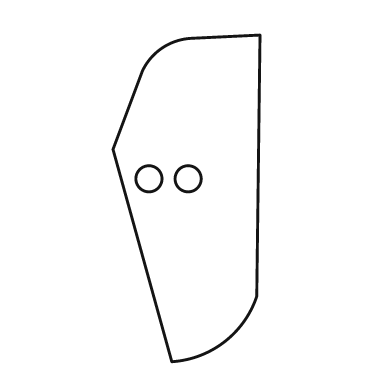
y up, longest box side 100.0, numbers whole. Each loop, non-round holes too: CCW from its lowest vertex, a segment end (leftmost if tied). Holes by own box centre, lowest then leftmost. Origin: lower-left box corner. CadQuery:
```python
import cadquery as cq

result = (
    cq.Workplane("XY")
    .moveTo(18.0, 0.0)
    .threePointArc((34.0, 6.0), (44.0, 20.0))
    .lineTo(45.0, 100.0)
    .lineTo(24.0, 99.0)
    .threePointArc((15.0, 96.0), (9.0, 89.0))
    .lineTo(0.0, 65.0)
    .close()
    .moveTo(11.0, 56.0)
    .circle(4.0)
    .moveTo(23.0, 56.0)
    .circle(4.0)
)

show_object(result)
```